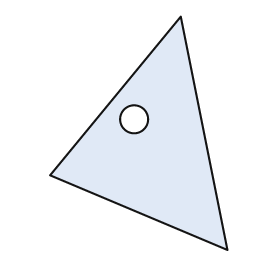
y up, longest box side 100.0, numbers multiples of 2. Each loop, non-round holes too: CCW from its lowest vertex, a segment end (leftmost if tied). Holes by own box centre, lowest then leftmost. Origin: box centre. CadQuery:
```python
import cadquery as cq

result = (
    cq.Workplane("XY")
    .moveTo(38.0, -50.0)
    .lineTo(18.0, 50.0)
    .lineTo(-38.0, -18.0)
    .close()
    .moveTo(-2.0, 6.0)
    .circle(6.0)
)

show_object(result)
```